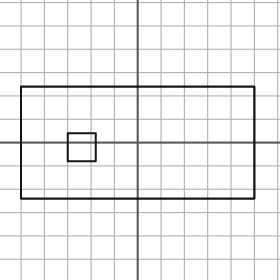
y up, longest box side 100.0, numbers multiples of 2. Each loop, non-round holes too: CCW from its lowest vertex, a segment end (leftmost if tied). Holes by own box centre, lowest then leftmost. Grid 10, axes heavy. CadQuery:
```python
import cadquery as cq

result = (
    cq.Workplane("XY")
    .moveTo(-50.0, -24.0)
    .lineTo(50.0, -24.0)
    .lineTo(50.0, 24.0)
    .lineTo(-50.0, 24.0)
    .close()
    .moveTo(-30.0, -8.0)
    .lineTo(-18.0, -8.0)
    .lineTo(-18.0, 4.0)
    .lineTo(-30.0, 4.0)
    .close()
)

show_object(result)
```